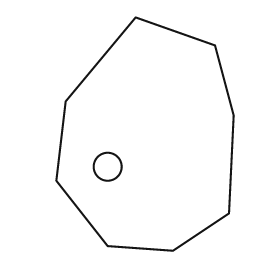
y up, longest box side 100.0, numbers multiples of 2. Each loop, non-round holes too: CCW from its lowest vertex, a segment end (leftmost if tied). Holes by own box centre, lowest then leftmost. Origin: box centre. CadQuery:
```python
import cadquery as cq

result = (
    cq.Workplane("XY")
    .moveTo(12.0, -50.0)
    .lineTo(36.0, -34.0)
    .lineTo(38.0, 8.0)
    .lineTo(30.0, 38.0)
    .lineTo(-4.0, 50.0)
    .lineTo(-34.0, 14.0)
    .lineTo(-38.0, -20.0)
    .lineTo(-16.0, -48.0)
    .close()
    .moveTo(-16.0, -14.0)
    .circle(6.0)
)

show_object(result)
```